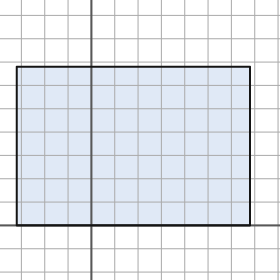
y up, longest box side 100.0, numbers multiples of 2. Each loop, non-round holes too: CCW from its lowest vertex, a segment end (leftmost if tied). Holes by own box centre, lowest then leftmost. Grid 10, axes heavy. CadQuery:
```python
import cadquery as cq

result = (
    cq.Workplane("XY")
    .moveTo(-32.0, 0.0)
    .lineTo(68.0, 0.0)
    .lineTo(68.0, 68.0)
    .lineTo(-32.0, 68.0)
    .close()
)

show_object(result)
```